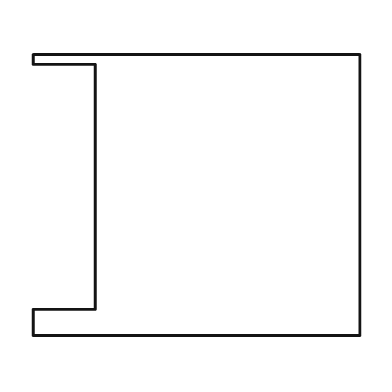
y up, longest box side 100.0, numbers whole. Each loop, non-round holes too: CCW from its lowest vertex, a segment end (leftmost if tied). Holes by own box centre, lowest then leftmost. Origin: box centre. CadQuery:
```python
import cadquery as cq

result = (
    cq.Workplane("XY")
    .moveTo(-50.0, -43.0)
    .lineTo(50.0, -43.0)
    .lineTo(50.0, 43.0)
    .lineTo(-50.0, 43.0)
    .lineTo(-50.0, 40.0)
    .lineTo(-31.0, 40.0)
    .lineTo(-31.0, -35.0)
    .lineTo(-50.0, -35.0)
    .close()
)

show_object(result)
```